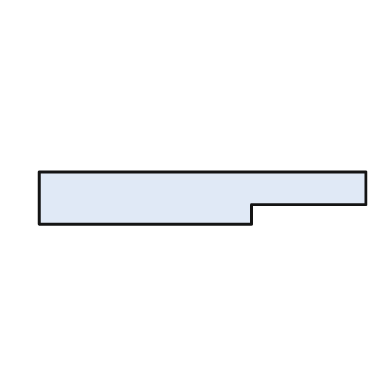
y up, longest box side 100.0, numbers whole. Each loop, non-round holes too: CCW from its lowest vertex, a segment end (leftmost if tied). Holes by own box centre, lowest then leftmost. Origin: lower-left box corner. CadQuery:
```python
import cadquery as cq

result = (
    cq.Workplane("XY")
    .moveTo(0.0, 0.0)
    .lineTo(65.0, 0.0)
    .lineTo(65.0, 6.0)
    .lineTo(100.0, 6.0)
    .lineTo(100.0, 16.0)
    .lineTo(0.0, 16.0)
    .close()
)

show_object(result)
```